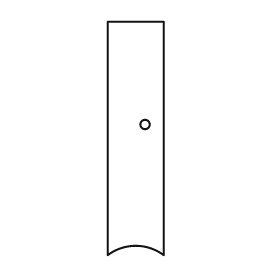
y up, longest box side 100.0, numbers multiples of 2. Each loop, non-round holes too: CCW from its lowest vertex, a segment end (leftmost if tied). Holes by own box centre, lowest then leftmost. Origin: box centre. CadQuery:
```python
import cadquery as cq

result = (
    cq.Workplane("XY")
    .moveTo(-12.0, -50.0)
    .threePointArc((0.0, -46.0), (12.0, -50.0))
    .lineTo(12.0, 50.0)
    .lineTo(-12.0, 50.0)
    .close()
    .moveTo(4.0, 6.0)
    .circle(2.0)
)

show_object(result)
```